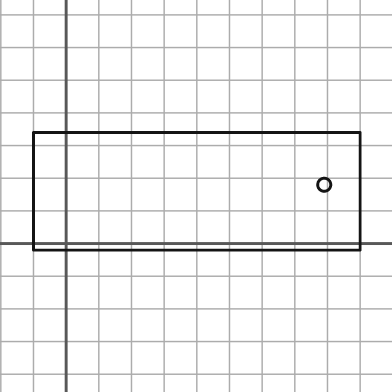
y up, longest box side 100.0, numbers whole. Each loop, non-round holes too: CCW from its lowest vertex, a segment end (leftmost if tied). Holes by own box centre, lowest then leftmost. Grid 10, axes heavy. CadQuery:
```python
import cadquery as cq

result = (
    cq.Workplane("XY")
    .moveTo(-10.0, -2.0)
    .lineTo(90.0, -2.0)
    .lineTo(90.0, 34.0)
    .lineTo(-10.0, 34.0)
    .close()
    .moveTo(79.0, 18.0)
    .circle(2.0)
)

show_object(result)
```